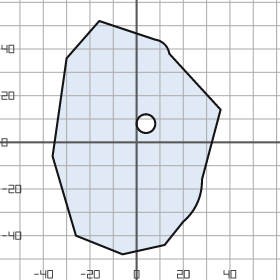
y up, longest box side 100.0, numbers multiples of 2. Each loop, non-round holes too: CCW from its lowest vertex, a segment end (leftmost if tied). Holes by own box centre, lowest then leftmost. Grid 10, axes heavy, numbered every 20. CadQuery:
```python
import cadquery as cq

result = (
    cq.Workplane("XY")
    .moveTo(-6.0, -48.0)
    .lineTo(12.0, -44.0)
    .lineTo(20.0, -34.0)
    .threePointArc((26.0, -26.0), (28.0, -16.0))
    .lineTo(36.0, 14.0)
    .lineTo(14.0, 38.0)
    .threePointArc((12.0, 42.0), (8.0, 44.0))
    .lineTo(-16.0, 52.0)
    .lineTo(-30.0, 36.0)
    .lineTo(-36.0, -6.0)
    .lineTo(-26.0, -40.0)
    .close()
    .moveTo(4.0, 8.0)
    .circle(4.0)
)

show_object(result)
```